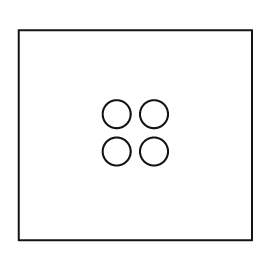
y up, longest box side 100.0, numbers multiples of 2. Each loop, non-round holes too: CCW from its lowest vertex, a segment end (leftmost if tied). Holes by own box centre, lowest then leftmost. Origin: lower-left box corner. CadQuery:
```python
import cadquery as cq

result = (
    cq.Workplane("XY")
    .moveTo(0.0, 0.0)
    .lineTo(100.0, 0.0)
    .lineTo(100.0, 90.0)
    .lineTo(0.0, 90.0)
    .close()
    .moveTo(42.0, 38.0)
    .circle(6.0)
    .moveTo(58.0, 38.0)
    .circle(6.0)
    .moveTo(42.0, 54.0)
    .circle(6.0)
    .moveTo(58.0, 54.0)
    .circle(6.0)
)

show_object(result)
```